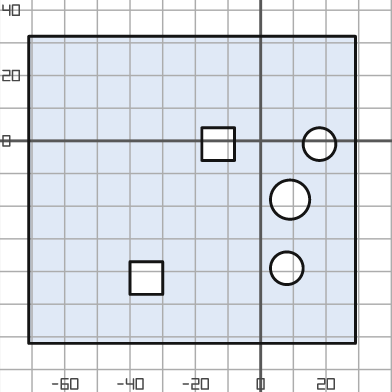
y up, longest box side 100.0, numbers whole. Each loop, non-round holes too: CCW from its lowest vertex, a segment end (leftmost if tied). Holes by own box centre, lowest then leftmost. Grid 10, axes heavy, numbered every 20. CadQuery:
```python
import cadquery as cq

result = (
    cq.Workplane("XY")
    .moveTo(-71.0, -62.0)
    .lineTo(29.0, -62.0)
    .lineTo(29.0, 32.0)
    .lineTo(-71.0, 32.0)
    .close()
    .moveTo(-40.0, -47.0)
    .lineTo(-30.0, -47.0)
    .lineTo(-30.0, -37.0)
    .lineTo(-40.0, -37.0)
    .close()
    .moveTo(8.0, -39.0)
    .circle(5.0)
    .moveTo(9.0, -18.0)
    .circle(6.0)
    .moveTo(-18.0, -6.0)
    .lineTo(-8.0, -6.0)
    .lineTo(-8.0, 4.0)
    .lineTo(-18.0, 4.0)
    .close()
    .moveTo(18.0, -1.0)
    .circle(5.0)
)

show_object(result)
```